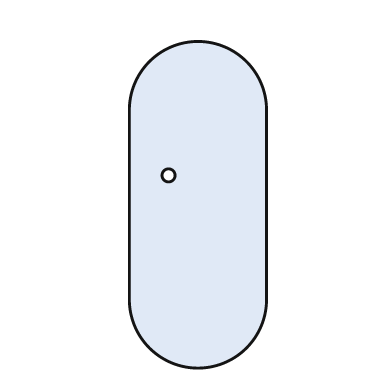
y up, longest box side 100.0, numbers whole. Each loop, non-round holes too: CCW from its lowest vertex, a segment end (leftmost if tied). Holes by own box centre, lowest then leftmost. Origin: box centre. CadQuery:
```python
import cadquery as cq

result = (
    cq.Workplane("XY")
    .moveTo(-21.0, -29.0)
    .threePointArc((0.0, -50.0), (21.0, -29.0))
    .lineTo(21.0, 29.0)
    .threePointArc((0.0, 50.0), (-21.0, 29.0))
    .close()
    .moveTo(-9.0, 9.0)
    .circle(2.0)
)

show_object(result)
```